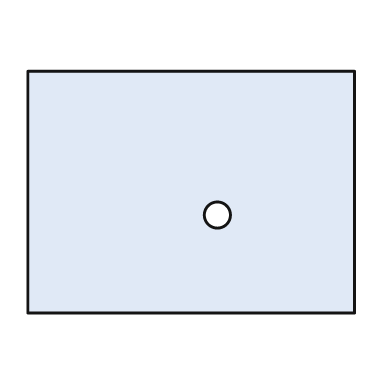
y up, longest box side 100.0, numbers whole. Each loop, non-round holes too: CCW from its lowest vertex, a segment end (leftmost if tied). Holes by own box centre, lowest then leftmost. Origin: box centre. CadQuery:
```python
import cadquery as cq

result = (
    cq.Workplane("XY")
    .moveTo(-50.0, -37.0)
    .lineTo(50.0, -37.0)
    .lineTo(50.0, 37.0)
    .lineTo(-50.0, 37.0)
    .close()
    .moveTo(8.0, -7.0)
    .circle(4.0)
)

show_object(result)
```